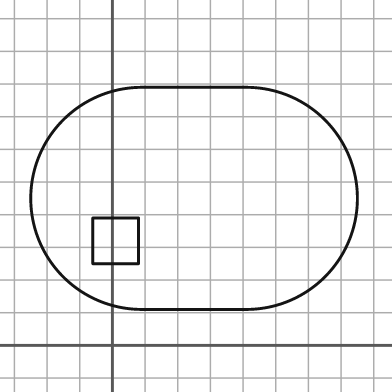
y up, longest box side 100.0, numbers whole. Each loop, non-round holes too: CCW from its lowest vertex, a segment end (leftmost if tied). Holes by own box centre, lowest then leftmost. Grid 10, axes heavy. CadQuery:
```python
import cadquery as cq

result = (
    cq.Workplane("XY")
    .moveTo(9.0, 11.0)
    .lineTo(41.0, 11.0)
    .threePointArc((75.0, 45.0), (41.0, 79.0))
    .lineTo(9.0, 79.0)
    .threePointArc((-25.0, 45.0), (9.0, 11.0))
    .close()
    .moveTo(-6.0, 25.0)
    .lineTo(8.0, 25.0)
    .lineTo(8.0, 39.0)
    .lineTo(-6.0, 39.0)
    .close()
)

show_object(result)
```